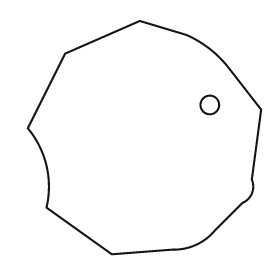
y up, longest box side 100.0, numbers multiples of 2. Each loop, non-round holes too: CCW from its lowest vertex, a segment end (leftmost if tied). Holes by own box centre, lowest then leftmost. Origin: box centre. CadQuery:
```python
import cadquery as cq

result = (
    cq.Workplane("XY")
    .moveTo(-14.0, -50.0)
    .lineTo(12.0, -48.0)
    .threePointArc((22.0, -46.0), (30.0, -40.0))
    .lineTo(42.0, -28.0)
    .threePointArc((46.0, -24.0), (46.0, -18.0))
    .lineTo(50.0, 12.0)
    .lineTo(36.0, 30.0)
    .threePointArc((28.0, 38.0), (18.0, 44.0))
    .lineTo(-2.0, 50.0)
    .lineTo(-34.0, 36.0)
    .lineTo(-50.0, 4.0)
    .threePointArc((-42.0, -12.0), (-42.0, -30.0))
    .close()
    .moveTo(28.0, 14.0)
    .circle(4.0)
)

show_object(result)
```